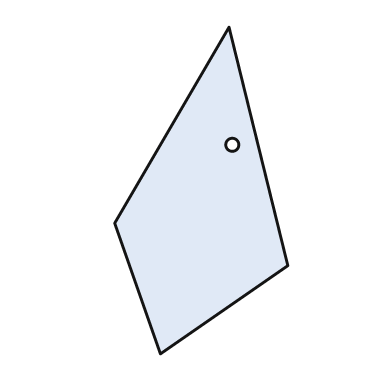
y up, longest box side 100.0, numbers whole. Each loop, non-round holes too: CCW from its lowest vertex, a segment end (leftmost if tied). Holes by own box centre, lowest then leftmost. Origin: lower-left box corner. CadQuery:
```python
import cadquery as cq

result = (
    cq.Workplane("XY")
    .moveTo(14.0, 0.0)
    .lineTo(53.0, 27.0)
    .lineTo(35.0, 100.0)
    .lineTo(0.0, 40.0)
    .close()
    .moveTo(36.0, 64.0)
    .circle(2.0)
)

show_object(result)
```